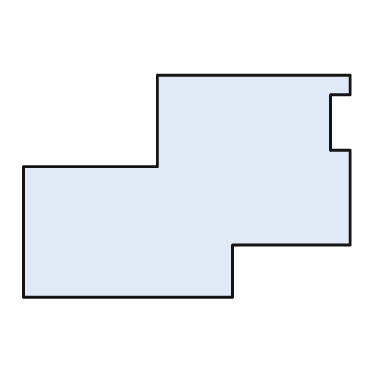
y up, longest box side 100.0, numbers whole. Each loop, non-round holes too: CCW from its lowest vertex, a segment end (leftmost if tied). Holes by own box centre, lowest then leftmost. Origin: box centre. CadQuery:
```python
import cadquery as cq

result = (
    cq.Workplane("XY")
    .moveTo(-50.0, -34.0)
    .lineTo(14.0, -34.0)
    .lineTo(14.0, -18.0)
    .lineTo(50.0, -18.0)
    .lineTo(50.0, 11.0)
    .lineTo(44.0, 11.0)
    .lineTo(44.0, 28.0)
    .lineTo(50.0, 28.0)
    .lineTo(50.0, 34.0)
    .lineTo(-9.0, 34.0)
    .lineTo(-9.0, 6.0)
    .lineTo(-50.0, 6.0)
    .close()
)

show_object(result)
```